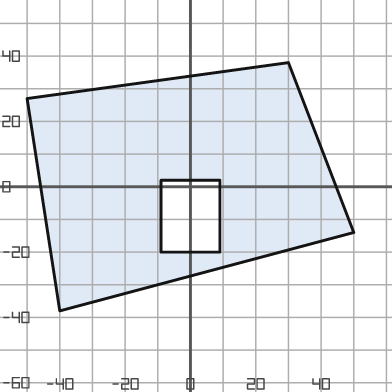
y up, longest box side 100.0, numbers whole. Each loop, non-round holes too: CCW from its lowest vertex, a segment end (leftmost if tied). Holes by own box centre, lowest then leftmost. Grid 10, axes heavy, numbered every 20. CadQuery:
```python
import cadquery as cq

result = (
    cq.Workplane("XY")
    .moveTo(-40.0, -38.0)
    .lineTo(50.0, -14.0)
    .lineTo(30.0, 38.0)
    .lineTo(-50.0, 27.0)
    .close()
    .moveTo(-9.0, -20.0)
    .lineTo(9.0, -20.0)
    .lineTo(9.0, 2.0)
    .lineTo(-9.0, 2.0)
    .close()
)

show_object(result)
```